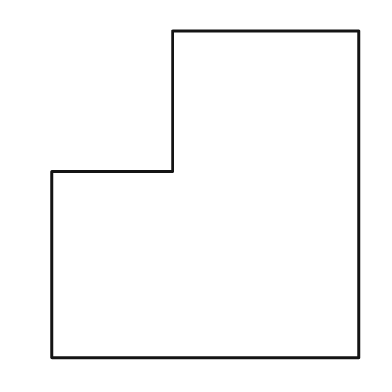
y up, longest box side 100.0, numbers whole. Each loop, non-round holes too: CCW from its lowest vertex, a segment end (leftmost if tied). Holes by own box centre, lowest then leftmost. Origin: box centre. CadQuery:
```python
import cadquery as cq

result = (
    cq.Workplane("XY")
    .moveTo(-47.0, -50.0)
    .lineTo(47.0, -50.0)
    .lineTo(47.0, 50.0)
    .lineTo(-10.0, 50.0)
    .lineTo(-10.0, 7.0)
    .lineTo(-47.0, 7.0)
    .close()
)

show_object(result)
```